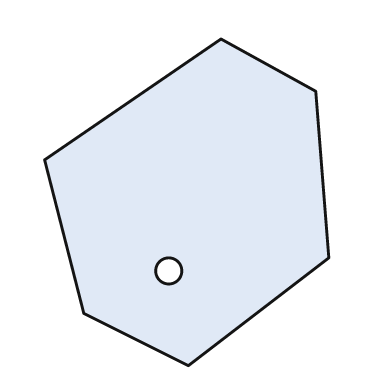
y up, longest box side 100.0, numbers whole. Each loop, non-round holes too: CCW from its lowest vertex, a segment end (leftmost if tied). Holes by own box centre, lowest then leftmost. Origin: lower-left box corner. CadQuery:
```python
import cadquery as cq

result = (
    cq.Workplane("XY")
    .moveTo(44.0, 0.0)
    .lineTo(87.0, 33.0)
    .lineTo(83.0, 84.0)
    .lineTo(54.0, 100.0)
    .lineTo(0.0, 63.0)
    .lineTo(12.0, 16.0)
    .close()
    .moveTo(38.0, 29.0)
    .circle(4.0)
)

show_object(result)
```